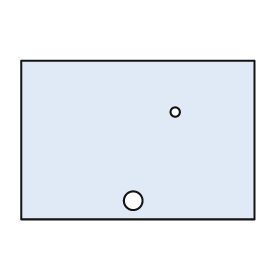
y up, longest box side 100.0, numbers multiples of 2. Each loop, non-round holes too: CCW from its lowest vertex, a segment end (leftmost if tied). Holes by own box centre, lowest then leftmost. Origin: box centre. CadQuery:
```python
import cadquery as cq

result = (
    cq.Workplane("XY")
    .moveTo(-50.0, -34.0)
    .lineTo(50.0, -34.0)
    .lineTo(50.0, 34.0)
    .lineTo(-50.0, 34.0)
    .close()
    .moveTo(-2.0, -26.0)
    .circle(4.0)
    .moveTo(16.0, 12.0)
    .circle(2.0)
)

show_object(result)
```